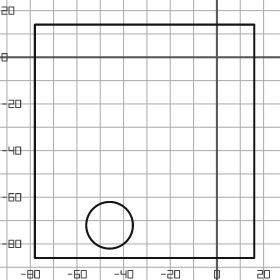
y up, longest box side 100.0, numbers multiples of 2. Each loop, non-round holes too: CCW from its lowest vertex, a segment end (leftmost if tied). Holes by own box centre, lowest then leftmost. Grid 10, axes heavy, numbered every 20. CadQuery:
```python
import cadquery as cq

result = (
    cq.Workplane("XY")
    .moveTo(-78.0, -86.0)
    .lineTo(16.0, -86.0)
    .lineTo(16.0, 14.0)
    .lineTo(-78.0, 14.0)
    .close()
    .moveTo(-46.0, -72.0)
    .circle(10.0)
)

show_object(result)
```